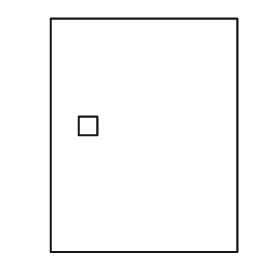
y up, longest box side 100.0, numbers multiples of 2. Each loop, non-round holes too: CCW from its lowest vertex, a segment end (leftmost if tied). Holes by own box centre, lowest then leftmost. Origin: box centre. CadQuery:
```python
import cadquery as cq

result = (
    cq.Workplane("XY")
    .moveTo(-40.0, -50.0)
    .lineTo(40.0, -50.0)
    .lineTo(40.0, 50.0)
    .lineTo(-40.0, 50.0)
    .close()
    .moveTo(-28.0, 0.0)
    .lineTo(-20.0, 0.0)
    .lineTo(-20.0, 8.0)
    .lineTo(-28.0, 8.0)
    .close()
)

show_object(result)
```